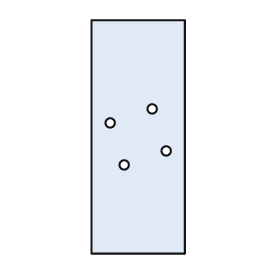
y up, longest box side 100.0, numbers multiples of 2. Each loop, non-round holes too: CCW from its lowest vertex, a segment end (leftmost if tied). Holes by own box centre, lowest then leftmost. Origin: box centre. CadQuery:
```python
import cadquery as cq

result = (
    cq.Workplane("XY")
    .moveTo(-20.0, -50.0)
    .lineTo(20.0, -50.0)
    .lineTo(20.0, 50.0)
    .lineTo(-20.0, 50.0)
    .close()
    .moveTo(-6.0, -12.0)
    .circle(2.0)
    .moveTo(12.0, -6.0)
    .circle(2.0)
    .moveTo(-12.0, 6.0)
    .circle(2.0)
    .moveTo(6.0, 12.0)
    .circle(2.0)
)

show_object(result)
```